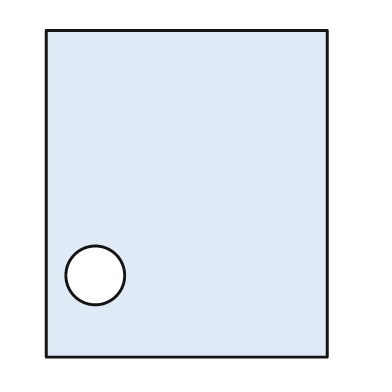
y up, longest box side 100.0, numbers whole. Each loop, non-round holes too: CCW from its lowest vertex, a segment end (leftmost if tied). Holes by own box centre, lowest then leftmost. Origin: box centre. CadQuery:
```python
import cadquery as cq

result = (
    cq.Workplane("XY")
    .moveTo(-43.0, -50.0)
    .lineTo(43.0, -50.0)
    .lineTo(43.0, 50.0)
    .lineTo(-43.0, 50.0)
    .close()
    .moveTo(-28.0, -25.0)
    .circle(9.0)
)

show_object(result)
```